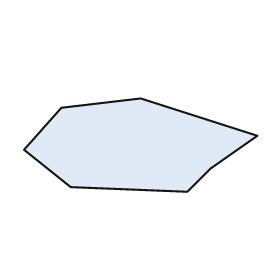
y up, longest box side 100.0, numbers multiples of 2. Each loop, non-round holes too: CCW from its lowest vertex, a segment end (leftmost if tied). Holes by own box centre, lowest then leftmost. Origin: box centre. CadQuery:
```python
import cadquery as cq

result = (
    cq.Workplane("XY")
    .moveTo(20.0, -20.0)
    .lineTo(30.0, -10.0)
    .lineTo(50.0, 4.0)
    .lineTo(0.0, 20.0)
    .lineTo(-34.0, 16.0)
    .lineTo(-50.0, -2.0)
    .lineTo(-30.0, -18.0)
    .close()
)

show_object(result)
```